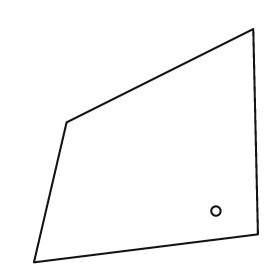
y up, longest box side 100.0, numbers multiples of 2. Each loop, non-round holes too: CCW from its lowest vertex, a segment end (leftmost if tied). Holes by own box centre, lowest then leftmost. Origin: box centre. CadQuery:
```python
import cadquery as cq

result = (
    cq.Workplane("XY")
    .moveTo(-48.0, -50.0)
    .lineTo(48.0, -38.0)
    .lineTo(46.0, 50.0)
    .lineTo(-34.0, 10.0)
    .close()
    .moveTo(30.0, -28.0)
    .circle(2.0)
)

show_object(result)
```